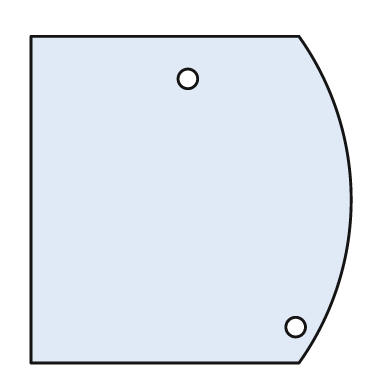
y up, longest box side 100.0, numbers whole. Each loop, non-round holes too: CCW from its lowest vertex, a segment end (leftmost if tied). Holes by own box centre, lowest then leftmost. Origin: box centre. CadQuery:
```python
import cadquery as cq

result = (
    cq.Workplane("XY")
    .moveTo(-49.0, -50.0)
    .lineTo(33.0, -50.0)
    .threePointArc((49.0, 0.0), (33.0, 50.0))
    .lineTo(-49.0, 50.0)
    .close()
    .moveTo(32.0, -39.0)
    .circle(3.0)
    .moveTo(-1.0, 37.0)
    .circle(3.0)
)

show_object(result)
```